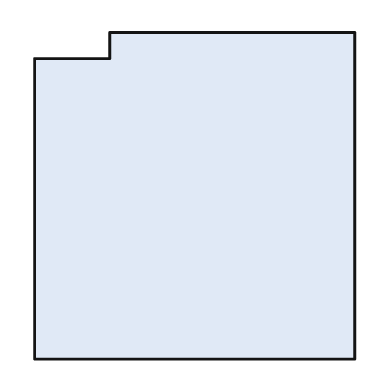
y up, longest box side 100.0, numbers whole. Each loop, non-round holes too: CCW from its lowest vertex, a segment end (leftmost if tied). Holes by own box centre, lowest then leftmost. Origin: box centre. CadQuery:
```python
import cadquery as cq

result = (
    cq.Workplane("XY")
    .moveTo(-49.0, -50.0)
    .lineTo(49.0, -50.0)
    .lineTo(49.0, 50.0)
    .lineTo(-26.0, 50.0)
    .lineTo(-26.0, 42.0)
    .lineTo(-49.0, 42.0)
    .close()
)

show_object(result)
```